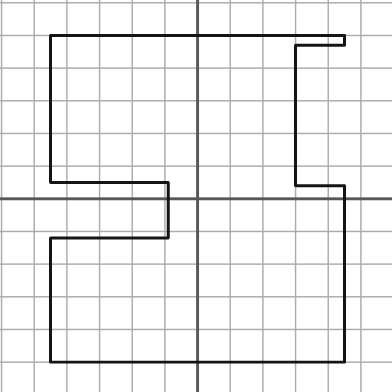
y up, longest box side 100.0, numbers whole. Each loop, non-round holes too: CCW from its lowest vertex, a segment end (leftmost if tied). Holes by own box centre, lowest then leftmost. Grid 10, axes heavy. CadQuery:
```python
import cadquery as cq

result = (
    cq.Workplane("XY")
    .moveTo(-45.0, -50.0)
    .lineTo(45.0, -50.0)
    .lineTo(45.0, 4.0)
    .lineTo(30.0, 4.0)
    .lineTo(30.0, 47.0)
    .lineTo(45.0, 47.0)
    .lineTo(45.0, 50.0)
    .lineTo(-45.0, 50.0)
    .lineTo(-45.0, 5.0)
    .lineTo(-9.0, 5.0)
    .lineTo(-9.0, -12.0)
    .lineTo(-45.0, -12.0)
    .close()
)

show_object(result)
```